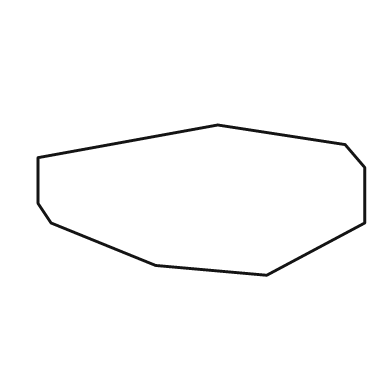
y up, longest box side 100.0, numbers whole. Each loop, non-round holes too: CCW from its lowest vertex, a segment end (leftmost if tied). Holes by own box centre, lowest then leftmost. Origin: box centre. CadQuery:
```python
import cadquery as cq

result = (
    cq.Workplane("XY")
    .moveTo(20.0, -23.0)
    .lineTo(50.0, -7.0)
    .lineTo(50.0, 10.0)
    .lineTo(44.0, 17.0)
    .lineTo(5.0, 23.0)
    .lineTo(-50.0, 13.0)
    .lineTo(-50.0, -1.0)
    .lineTo(-46.0, -7.0)
    .lineTo(-14.0, -20.0)
    .close()
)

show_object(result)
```